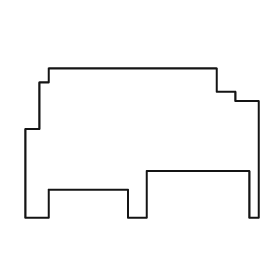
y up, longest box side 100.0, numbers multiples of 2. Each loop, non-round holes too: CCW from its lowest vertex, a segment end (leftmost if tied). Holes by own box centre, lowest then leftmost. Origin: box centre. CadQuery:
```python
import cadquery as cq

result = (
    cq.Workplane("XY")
    .moveTo(-50.0, -32.0)
    .lineTo(-40.0, -32.0)
    .lineTo(-40.0, -20.0)
    .lineTo(-6.0, -20.0)
    .lineTo(-6.0, -32.0)
    .lineTo(2.0, -32.0)
    .lineTo(2.0, -12.0)
    .lineTo(46.0, -12.0)
    .lineTo(46.0, -32.0)
    .lineTo(50.0, -32.0)
    .lineTo(50.0, 18.0)
    .lineTo(40.0, 18.0)
    .lineTo(40.0, 22.0)
    .lineTo(32.0, 22.0)
    .lineTo(32.0, 32.0)
    .lineTo(-40.0, 32.0)
    .lineTo(-40.0, 26.0)
    .lineTo(-44.0, 26.0)
    .lineTo(-44.0, 6.0)
    .lineTo(-50.0, 6.0)
    .close()
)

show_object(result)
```